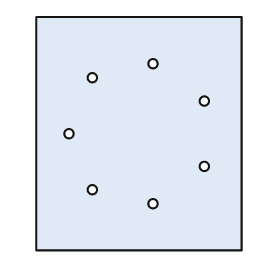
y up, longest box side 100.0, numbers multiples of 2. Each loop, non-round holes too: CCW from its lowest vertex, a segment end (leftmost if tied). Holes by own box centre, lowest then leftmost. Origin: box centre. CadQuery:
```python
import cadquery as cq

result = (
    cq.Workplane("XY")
    .moveTo(-44.0, -50.0)
    .lineTo(44.0, -50.0)
    .lineTo(44.0, 50.0)
    .lineTo(-44.0, 50.0)
    .close()
    .moveTo(6.0, -30.0)
    .circle(2.0)
    .moveTo(-20.0, -24.0)
    .circle(2.0)
    .moveTo(28.0, -14.0)
    .circle(2.0)
    .moveTo(-30.0, 0.0)
    .circle(2.0)
    .moveTo(28.0, 14.0)
    .circle(2.0)
    .moveTo(-20.0, 24.0)
    .circle(2.0)
    .moveTo(6.0, 30.0)
    .circle(2.0)
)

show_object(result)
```